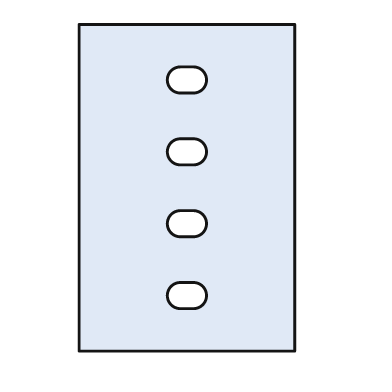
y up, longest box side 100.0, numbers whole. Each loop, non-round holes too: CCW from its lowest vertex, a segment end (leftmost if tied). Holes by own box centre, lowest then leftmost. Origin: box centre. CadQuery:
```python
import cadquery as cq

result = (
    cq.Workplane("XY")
    .moveTo(-33.0, -50.0)
    .lineTo(33.0, -50.0)
    .lineTo(33.0, 50.0)
    .lineTo(-33.0, 50.0)
    .close()
    .moveTo(-2.0, -37.0)
    .lineTo(2.0, -37.0)
    .threePointArc((6.0, -33.0), (2.0, -29.0))
    .lineTo(-2.0, -29.0)
    .threePointArc((-6.0, -33.0), (-2.0, -37.0))
    .close()
    .moveTo(-2.0, -15.0)
    .lineTo(2.0, -15.0)
    .threePointArc((6.0, -11.0), (2.0, -7.0))
    .lineTo(-2.0, -7.0)
    .threePointArc((-6.0, -11.0), (-2.0, -15.0))
    .close()
    .moveTo(-2.0, 7.0)
    .lineTo(2.0, 7.0)
    .threePointArc((6.0, 11.0), (2.0, 15.0))
    .lineTo(-2.0, 15.0)
    .threePointArc((-6.0, 11.0), (-2.0, 7.0))
    .close()
    .moveTo(-2.0, 29.0)
    .lineTo(2.0, 29.0)
    .threePointArc((6.0, 33.0), (2.0, 37.0))
    .lineTo(-2.0, 37.0)
    .threePointArc((-6.0, 33.0), (-2.0, 29.0))
    .close()
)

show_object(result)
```